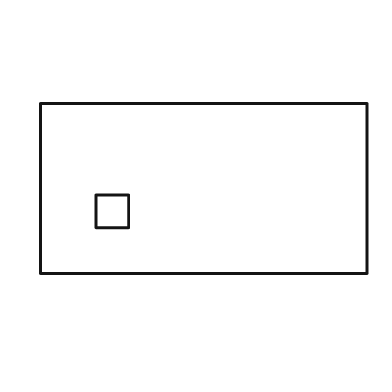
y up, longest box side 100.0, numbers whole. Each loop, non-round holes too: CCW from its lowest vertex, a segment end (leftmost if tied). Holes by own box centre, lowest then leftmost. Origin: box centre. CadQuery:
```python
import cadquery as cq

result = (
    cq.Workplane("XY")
    .moveTo(-50.0, -26.0)
    .lineTo(50.0, -26.0)
    .lineTo(50.0, 26.0)
    .lineTo(-50.0, 26.0)
    .close()
    .moveTo(-33.0, -12.0)
    .lineTo(-23.0, -12.0)
    .lineTo(-23.0, -2.0)
    .lineTo(-33.0, -2.0)
    .close()
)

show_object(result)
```